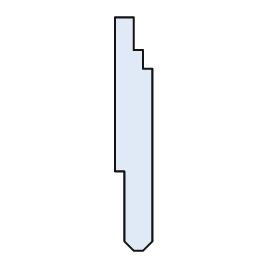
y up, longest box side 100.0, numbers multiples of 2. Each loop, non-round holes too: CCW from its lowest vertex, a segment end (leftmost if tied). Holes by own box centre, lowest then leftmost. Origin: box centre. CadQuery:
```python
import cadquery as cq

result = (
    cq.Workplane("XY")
    .moveTo(0.0, -50.0)
    .lineTo(4.0, -50.0)
    .lineTo(8.0, -46.0)
    .lineTo(8.0, 28.0)
    .lineTo(4.0, 28.0)
    .lineTo(4.0, 36.0)
    .lineTo(0.0, 36.0)
    .lineTo(0.0, 50.0)
    .lineTo(-8.0, 50.0)
    .lineTo(-8.0, -16.0)
    .lineTo(-4.0, -16.0)
    .lineTo(-4.0, -46.0)
    .close()
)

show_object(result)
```